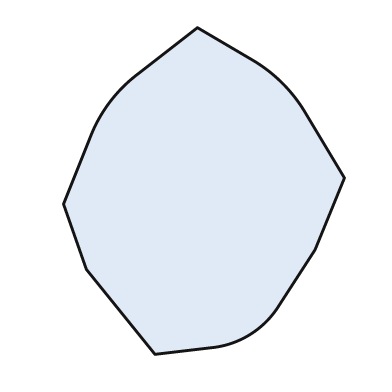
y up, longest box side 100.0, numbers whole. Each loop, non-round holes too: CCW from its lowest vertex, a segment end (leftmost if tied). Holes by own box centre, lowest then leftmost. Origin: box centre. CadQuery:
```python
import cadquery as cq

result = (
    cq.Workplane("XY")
    .moveTo(-15.0, -50.0)
    .lineTo(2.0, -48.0)
    .threePointArc((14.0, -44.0), (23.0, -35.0))
    .lineTo(34.0, -18.0)
    .lineTo(43.0, 4.0)
    .lineTo(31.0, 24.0)
    .threePointArc((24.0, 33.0), (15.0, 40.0))
    .lineTo(-2.0, 50.0)
    .lineTo(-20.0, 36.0)
    .threePointArc((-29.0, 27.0), (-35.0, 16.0))
    .lineTo(-43.0, -4.0)
    .lineTo(-36.0, -24.0)
    .close()
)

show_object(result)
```